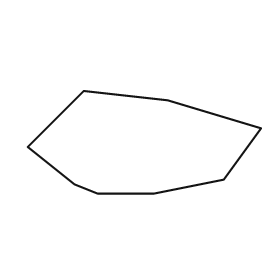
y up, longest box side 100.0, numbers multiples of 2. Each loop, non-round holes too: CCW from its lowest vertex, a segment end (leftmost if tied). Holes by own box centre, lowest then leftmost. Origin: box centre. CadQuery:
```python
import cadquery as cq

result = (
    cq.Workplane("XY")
    .moveTo(-20.0, -22.0)
    .lineTo(4.0, -22.0)
    .lineTo(34.0, -16.0)
    .lineTo(50.0, 6.0)
    .lineTo(10.0, 18.0)
    .lineTo(-26.0, 22.0)
    .lineTo(-50.0, -2.0)
    .lineTo(-30.0, -18.0)
    .close()
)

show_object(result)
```